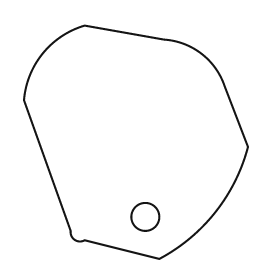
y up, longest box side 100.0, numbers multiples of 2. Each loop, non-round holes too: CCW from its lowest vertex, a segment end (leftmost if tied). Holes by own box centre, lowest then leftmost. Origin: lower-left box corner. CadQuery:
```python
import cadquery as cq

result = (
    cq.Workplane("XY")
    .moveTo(58.0, 0.0)
    .threePointArc((82.0, 20.0), (96.0, 48.0))
    .lineTo(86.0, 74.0)
    .threePointArc((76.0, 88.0), (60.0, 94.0))
    .lineTo(26.0, 100.0)
    .threePointArc((8.0, 88.0), (0.0, 68.0))
    .lineTo(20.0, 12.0)
    .threePointArc((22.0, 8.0), (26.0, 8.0))
    .close()
    .moveTo(52.0, 18.0)
    .circle(6.0)
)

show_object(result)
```